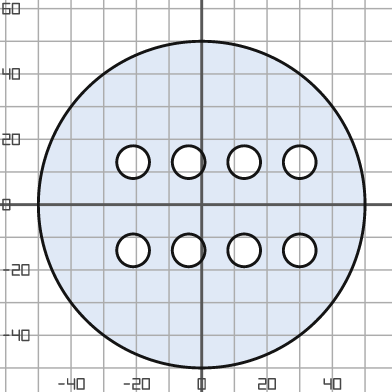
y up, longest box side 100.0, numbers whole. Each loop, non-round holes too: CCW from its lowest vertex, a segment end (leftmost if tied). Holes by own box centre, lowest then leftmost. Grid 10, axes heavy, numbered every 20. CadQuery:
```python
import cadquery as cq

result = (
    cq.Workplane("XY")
    .moveTo(0.0, 0.0)
    .circle(50.0)
    .moveTo(-21.0, -14.0)
    .circle(5.0)
    .moveTo(-4.0, -14.0)
    .circle(5.0)
    .moveTo(13.0, -14.0)
    .circle(5.0)
    .moveTo(30.0, -14.0)
    .circle(5.0)
    .moveTo(-21.0, 13.0)
    .circle(5.0)
    .moveTo(-4.0, 13.0)
    .circle(5.0)
    .moveTo(13.0, 13.0)
    .circle(5.0)
    .moveTo(30.0, 13.0)
    .circle(5.0)
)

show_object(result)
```